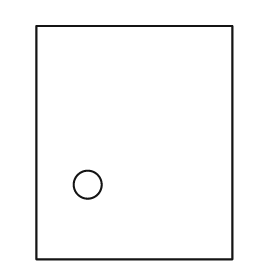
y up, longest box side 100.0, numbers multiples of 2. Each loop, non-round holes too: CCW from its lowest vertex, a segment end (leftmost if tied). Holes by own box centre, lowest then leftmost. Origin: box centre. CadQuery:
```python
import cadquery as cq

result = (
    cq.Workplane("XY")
    .moveTo(-42.0, -50.0)
    .lineTo(42.0, -50.0)
    .lineTo(42.0, 50.0)
    .lineTo(-42.0, 50.0)
    .close()
    .moveTo(-20.0, -18.0)
    .circle(6.0)
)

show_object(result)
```